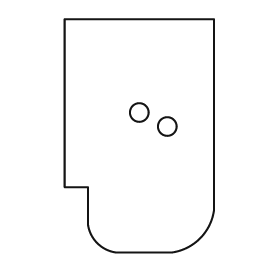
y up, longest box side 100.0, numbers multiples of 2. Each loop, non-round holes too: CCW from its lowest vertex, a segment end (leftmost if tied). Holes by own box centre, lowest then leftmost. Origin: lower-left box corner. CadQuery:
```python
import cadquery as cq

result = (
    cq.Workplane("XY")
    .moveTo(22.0, 0.0)
    .lineTo(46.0, 0.0)
    .threePointArc((58.0, 6.0), (64.0, 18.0))
    .lineTo(64.0, 100.0)
    .lineTo(0.0, 100.0)
    .lineTo(0.0, 28.0)
    .lineTo(10.0, 28.0)
    .lineTo(10.0, 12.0)
    .threePointArc((14.0, 4.0), (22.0, 0.0))
    .close()
    .moveTo(44.0, 54.0)
    .circle(4.0)
    .moveTo(32.0, 60.0)
    .circle(4.0)
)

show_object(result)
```